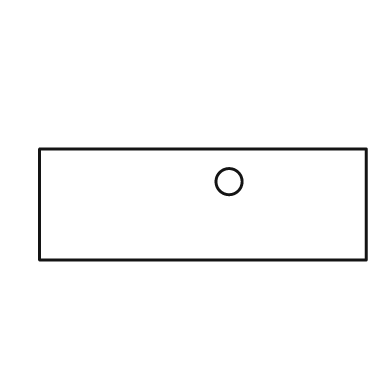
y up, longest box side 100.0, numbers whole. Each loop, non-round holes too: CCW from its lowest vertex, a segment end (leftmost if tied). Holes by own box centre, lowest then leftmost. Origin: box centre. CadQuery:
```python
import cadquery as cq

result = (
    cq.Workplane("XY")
    .moveTo(-50.0, -17.0)
    .lineTo(50.0, -17.0)
    .lineTo(50.0, 17.0)
    .lineTo(-50.0, 17.0)
    .close()
    .moveTo(8.0, 7.0)
    .circle(4.0)
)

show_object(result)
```